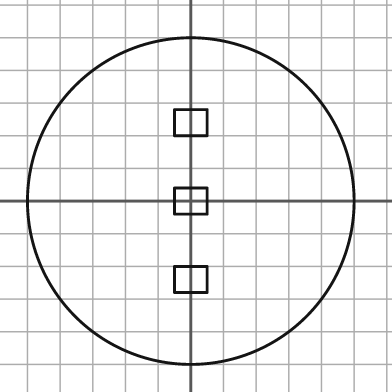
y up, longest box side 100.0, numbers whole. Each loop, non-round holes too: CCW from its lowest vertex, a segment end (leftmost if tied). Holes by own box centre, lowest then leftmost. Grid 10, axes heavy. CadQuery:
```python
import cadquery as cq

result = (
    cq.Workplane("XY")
    .moveTo(0.0, 0.0)
    .circle(50.0)
    .moveTo(-5.0, -28.0)
    .lineTo(5.0, -28.0)
    .lineTo(5.0, -20.0)
    .lineTo(-5.0, -20.0)
    .close()
    .moveTo(-5.0, -4.0)
    .lineTo(5.0, -4.0)
    .lineTo(5.0, 4.0)
    .lineTo(-5.0, 4.0)
    .close()
    .moveTo(-5.0, 20.0)
    .lineTo(5.0, 20.0)
    .lineTo(5.0, 28.0)
    .lineTo(-5.0, 28.0)
    .close()
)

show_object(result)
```